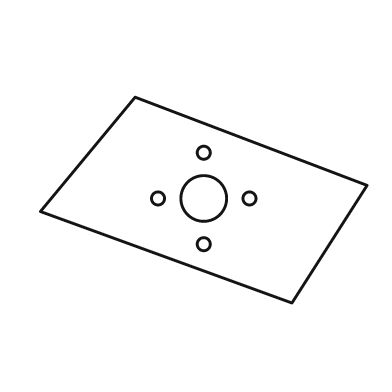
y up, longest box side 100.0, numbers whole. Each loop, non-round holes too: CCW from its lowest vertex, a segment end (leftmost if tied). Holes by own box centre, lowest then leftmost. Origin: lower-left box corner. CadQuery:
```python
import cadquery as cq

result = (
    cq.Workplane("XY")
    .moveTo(77.0, 0.0)
    .lineTo(100.0, 36.0)
    .lineTo(29.0, 63.0)
    .lineTo(0.0, 28.0)
    .close()
    .moveTo(50.0, 18.0)
    .circle(2.0)
    .moveTo(36.0, 32.0)
    .circle(2.0)
    .moveTo(50.0, 32.0)
    .circle(7.0)
    .moveTo(64.0, 32.0)
    .circle(2.0)
    .moveTo(50.0, 46.0)
    .circle(2.0)
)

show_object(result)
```